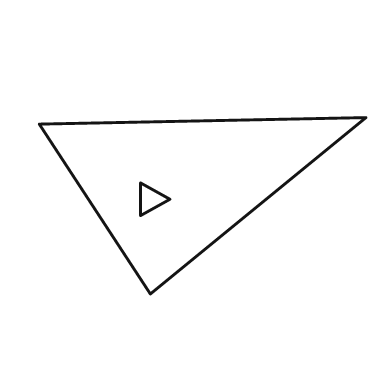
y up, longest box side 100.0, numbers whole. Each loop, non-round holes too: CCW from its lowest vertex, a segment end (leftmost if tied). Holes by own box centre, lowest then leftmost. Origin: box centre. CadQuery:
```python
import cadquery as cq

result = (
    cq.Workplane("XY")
    .moveTo(-16.0, -27.0)
    .lineTo(50.0, 27.0)
    .lineTo(-50.0, 25.0)
    .close()
    .moveTo(-19.0, -3.0)
    .lineTo(-10.0, 2.0)
    .lineTo(-19.0, 7.0)
    .close()
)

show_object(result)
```